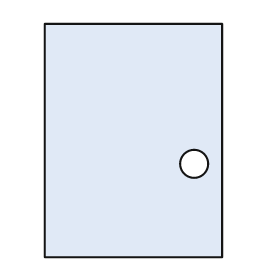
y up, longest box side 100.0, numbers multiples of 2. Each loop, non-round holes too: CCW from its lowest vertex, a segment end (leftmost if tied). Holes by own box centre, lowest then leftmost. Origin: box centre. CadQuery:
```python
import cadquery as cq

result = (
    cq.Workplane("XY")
    .moveTo(-38.0, -50.0)
    .lineTo(38.0, -50.0)
    .lineTo(38.0, 50.0)
    .lineTo(-38.0, 50.0)
    .close()
    .moveTo(26.0, -10.0)
    .circle(6.0)
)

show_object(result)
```